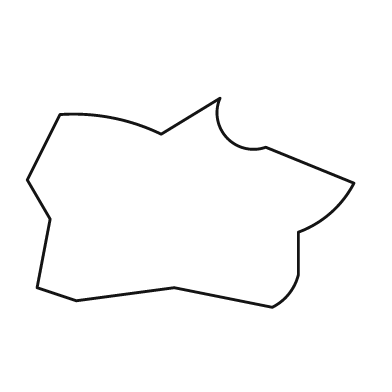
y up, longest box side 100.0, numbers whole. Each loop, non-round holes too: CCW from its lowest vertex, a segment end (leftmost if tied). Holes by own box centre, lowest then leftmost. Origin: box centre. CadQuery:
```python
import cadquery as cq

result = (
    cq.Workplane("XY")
    .moveTo(25.0, -32.0)
    .threePointArc((30.0, -28.0), (33.0, -22.0))
    .lineTo(33.0, -9.0)
    .threePointArc((43.0, -3.0), (50.0, 6.0))
    .lineTo(23.0, 17.0)
    .threePointArc((11.0, 20.0), (9.0, 32.0))
    .lineTo(-9.0, 21.0)
    .threePointArc((-24.0, 26.0), (-40.0, 27.0))
    .lineTo(-50.0, 7.0)
    .lineTo(-43.0, -5.0)
    .lineTo(-47.0, -26.0)
    .lineTo(-35.0, -30.0)
    .lineTo(-5.0, -26.0)
    .close()
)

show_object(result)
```